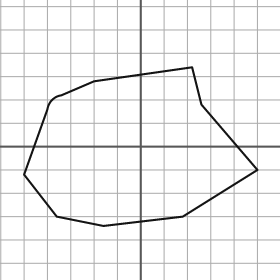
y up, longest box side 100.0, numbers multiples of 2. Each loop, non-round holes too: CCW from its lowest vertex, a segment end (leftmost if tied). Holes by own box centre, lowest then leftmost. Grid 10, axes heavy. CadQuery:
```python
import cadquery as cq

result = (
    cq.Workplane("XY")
    .moveTo(-16.0, -34.0)
    .lineTo(18.0, -30.0)
    .lineTo(50.0, -10.0)
    .lineTo(26.0, 18.0)
    .lineTo(22.0, 34.0)
    .lineTo(-20.0, 28.0)
    .lineTo(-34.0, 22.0)
    .threePointArc((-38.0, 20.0), (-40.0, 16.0))
    .lineTo(-50.0, -12.0)
    .lineTo(-36.0, -30.0)
    .close()
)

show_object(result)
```